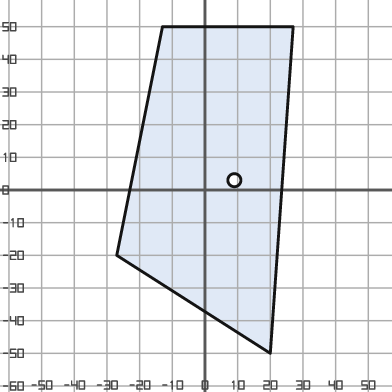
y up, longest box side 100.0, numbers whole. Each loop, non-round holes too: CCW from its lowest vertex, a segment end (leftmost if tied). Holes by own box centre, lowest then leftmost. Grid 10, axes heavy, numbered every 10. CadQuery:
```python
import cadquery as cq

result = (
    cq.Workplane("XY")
    .moveTo(20.0, -50.0)
    .lineTo(27.0, 50.0)
    .lineTo(-13.0, 50.0)
    .lineTo(-27.0, -20.0)
    .close()
    .moveTo(9.0, 3.0)
    .circle(2.0)
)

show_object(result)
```